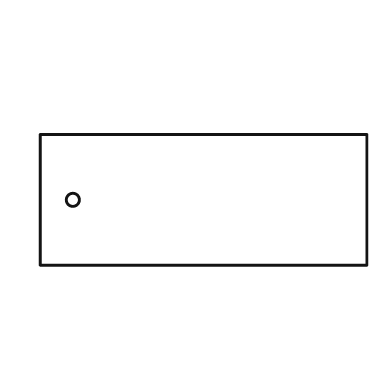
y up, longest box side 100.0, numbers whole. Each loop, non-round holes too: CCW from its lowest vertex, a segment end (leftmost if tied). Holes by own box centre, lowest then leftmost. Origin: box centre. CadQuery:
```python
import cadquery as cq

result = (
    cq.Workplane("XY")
    .moveTo(-50.0, -20.0)
    .lineTo(50.0, -20.0)
    .lineTo(50.0, 20.0)
    .lineTo(-50.0, 20.0)
    .close()
    .moveTo(-40.0, 0.0)
    .circle(2.0)
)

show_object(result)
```